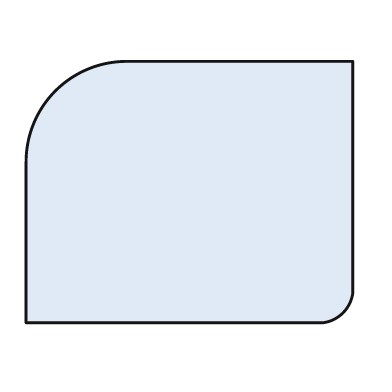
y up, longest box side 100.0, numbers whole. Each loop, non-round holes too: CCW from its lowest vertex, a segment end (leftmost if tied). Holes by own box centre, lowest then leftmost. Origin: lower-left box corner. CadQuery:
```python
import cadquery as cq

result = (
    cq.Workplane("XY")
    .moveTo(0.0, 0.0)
    .lineTo(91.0, 0.0)
    .threePointArc((97.0, 3.0), (100.0, 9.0))
    .lineTo(100.0, 80.0)
    .lineTo(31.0, 80.0)
    .threePointArc((9.0, 71.0), (0.0, 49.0))
    .close()
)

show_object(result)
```